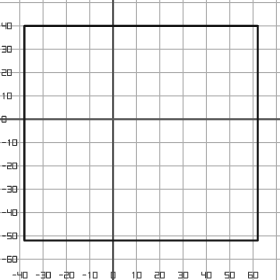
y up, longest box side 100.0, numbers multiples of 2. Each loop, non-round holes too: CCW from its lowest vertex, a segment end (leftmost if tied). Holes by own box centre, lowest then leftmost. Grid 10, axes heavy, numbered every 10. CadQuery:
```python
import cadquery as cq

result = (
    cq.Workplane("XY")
    .moveTo(-38.0, -52.0)
    .lineTo(62.0, -52.0)
    .lineTo(62.0, 40.0)
    .lineTo(-38.0, 40.0)
    .close()
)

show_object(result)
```